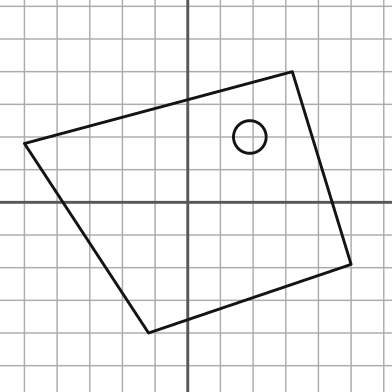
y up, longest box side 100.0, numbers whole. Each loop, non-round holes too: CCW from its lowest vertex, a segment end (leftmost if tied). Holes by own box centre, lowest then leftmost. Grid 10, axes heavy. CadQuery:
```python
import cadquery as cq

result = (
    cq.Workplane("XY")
    .moveTo(-12.0, -40.0)
    .lineTo(50.0, -19.0)
    .lineTo(32.0, 40.0)
    .lineTo(-50.0, 18.0)
    .close()
    .moveTo(19.0, 20.0)
    .circle(5.0)
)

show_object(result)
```